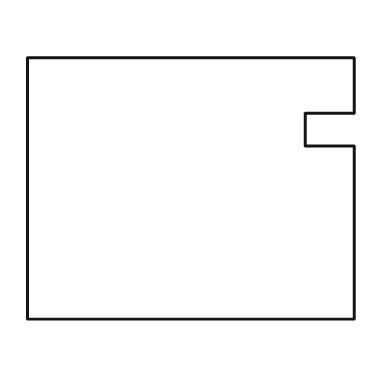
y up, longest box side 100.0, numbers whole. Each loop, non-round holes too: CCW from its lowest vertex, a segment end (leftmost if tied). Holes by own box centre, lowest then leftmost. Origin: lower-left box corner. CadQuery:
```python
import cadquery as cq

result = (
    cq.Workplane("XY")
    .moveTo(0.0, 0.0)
    .lineTo(100.0, 0.0)
    .lineTo(100.0, 53.0)
    .lineTo(85.0, 53.0)
    .lineTo(85.0, 63.0)
    .lineTo(100.0, 63.0)
    .lineTo(100.0, 80.0)
    .lineTo(0.0, 80.0)
    .close()
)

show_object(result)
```